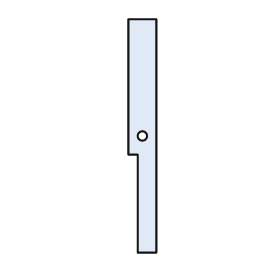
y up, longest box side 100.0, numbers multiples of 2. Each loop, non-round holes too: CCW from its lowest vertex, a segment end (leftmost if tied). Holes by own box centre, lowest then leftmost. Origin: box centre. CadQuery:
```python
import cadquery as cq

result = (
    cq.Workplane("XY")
    .moveTo(-2.0, -50.0)
    .lineTo(6.0, -50.0)
    .lineTo(6.0, 50.0)
    .lineTo(-6.0, 50.0)
    .lineTo(-6.0, -8.0)
    .lineTo(-2.0, -8.0)
    .close()
    .moveTo(0.0, 0.0)
    .circle(2.0)
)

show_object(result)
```